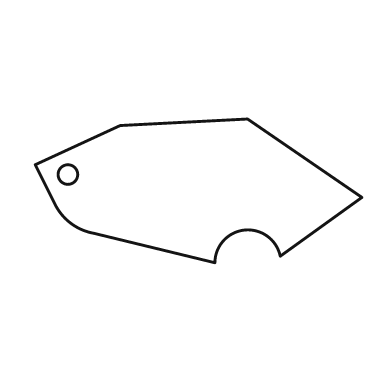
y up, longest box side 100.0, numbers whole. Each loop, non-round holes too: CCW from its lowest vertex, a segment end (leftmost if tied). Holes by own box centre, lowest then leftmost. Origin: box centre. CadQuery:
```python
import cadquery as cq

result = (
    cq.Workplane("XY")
    .moveTo(5.0, -22.0)
    .threePointArc((14.0, -12.0), (25.0, -20.0))
    .lineTo(50.0, -2.0)
    .lineTo(15.0, 22.0)
    .lineTo(-24.0, 20.0)
    .lineTo(-50.0, 8.0)
    .lineTo(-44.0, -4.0)
    .threePointArc((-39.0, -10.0), (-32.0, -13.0))
    .close()
    .moveTo(-40.0, 5.0)
    .circle(3.0)
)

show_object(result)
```